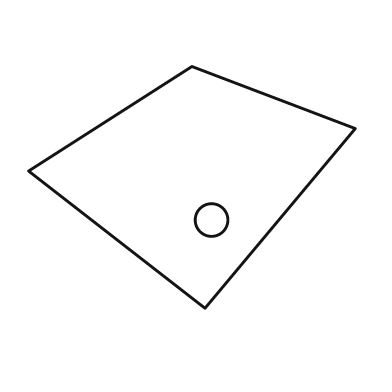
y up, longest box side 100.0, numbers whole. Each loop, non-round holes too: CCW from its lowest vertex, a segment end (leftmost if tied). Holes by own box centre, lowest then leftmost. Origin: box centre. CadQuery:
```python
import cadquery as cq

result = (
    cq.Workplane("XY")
    .moveTo(4.0, -37.0)
    .lineTo(50.0, 18.0)
    .lineTo(0.0, 37.0)
    .lineTo(-50.0, 5.0)
    .close()
    .moveTo(6.0, -10.0)
    .circle(5.0)
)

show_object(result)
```